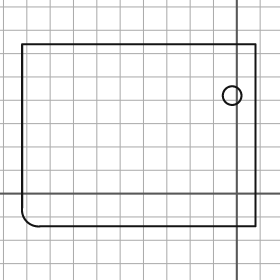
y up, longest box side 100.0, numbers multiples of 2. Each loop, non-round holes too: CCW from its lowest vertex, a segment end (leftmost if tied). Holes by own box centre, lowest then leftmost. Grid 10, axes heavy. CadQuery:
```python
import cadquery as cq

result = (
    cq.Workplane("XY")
    .moveTo(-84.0, -14.0)
    .lineTo(8.0, -14.0)
    .lineTo(8.0, 64.0)
    .lineTo(-92.0, 64.0)
    .lineTo(-92.0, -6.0)
    .threePointArc((-90.0, -12.0), (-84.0, -14.0))
    .close()
    .moveTo(-2.0, 42.0)
    .circle(4.0)
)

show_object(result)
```